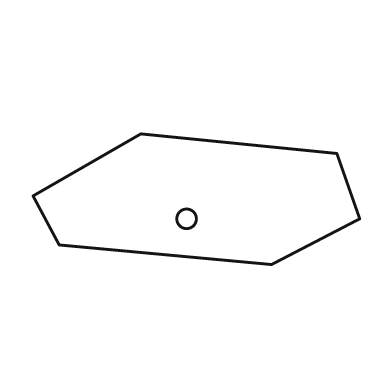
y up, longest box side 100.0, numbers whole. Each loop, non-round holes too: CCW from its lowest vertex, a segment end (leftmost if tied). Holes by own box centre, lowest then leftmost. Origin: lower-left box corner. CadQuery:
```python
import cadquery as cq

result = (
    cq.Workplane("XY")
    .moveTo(73.0, 0.0)
    .lineTo(100.0, 14.0)
    .lineTo(93.0, 34.0)
    .lineTo(33.0, 40.0)
    .lineTo(0.0, 21.0)
    .lineTo(8.0, 6.0)
    .close()
    .moveTo(47.0, 14.0)
    .circle(3.0)
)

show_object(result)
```